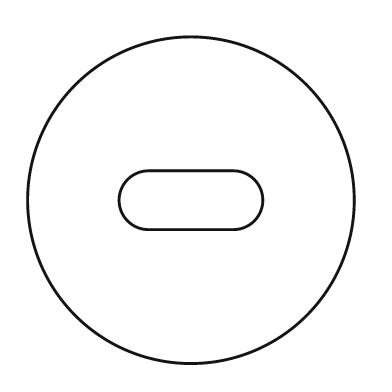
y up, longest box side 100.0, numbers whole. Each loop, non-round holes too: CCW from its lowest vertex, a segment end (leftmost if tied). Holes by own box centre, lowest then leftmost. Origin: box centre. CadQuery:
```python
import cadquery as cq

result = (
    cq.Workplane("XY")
    .moveTo(0.0, 0.0)
    .circle(50.0)
    .moveTo(-13.0, -9.0)
    .lineTo(13.0, -9.0)
    .threePointArc((22.0, 0.0), (13.0, 9.0))
    .lineTo(-13.0, 9.0)
    .threePointArc((-22.0, 0.0), (-13.0, -9.0))
    .close()
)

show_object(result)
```